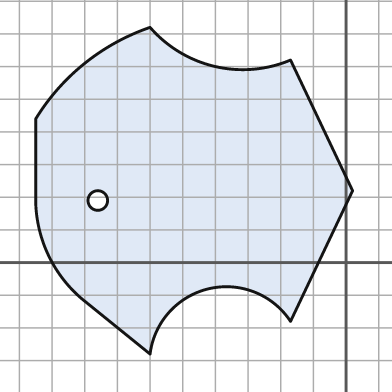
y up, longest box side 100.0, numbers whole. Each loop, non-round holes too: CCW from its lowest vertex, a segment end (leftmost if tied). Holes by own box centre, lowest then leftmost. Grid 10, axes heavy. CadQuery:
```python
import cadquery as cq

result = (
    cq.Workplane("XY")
    .moveTo(-60.0, -28.0)
    .threePointArc((-42.0, -8.0), (-17.0, -18.0))
    .lineTo(2.0, 22.0)
    .lineTo(-17.0, 62.0)
    .threePointArc((-40.0, 60.0), (-60.0, 72.0))
    .threePointArc((-80.0, 61.0), (-95.0, 44.0))
    .lineTo(-95.0, 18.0)
    .threePointArc((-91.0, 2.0), (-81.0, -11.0))
    .close()
    .moveTo(-76.0, 19.0)
    .circle(3.0)
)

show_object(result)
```